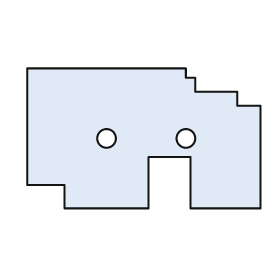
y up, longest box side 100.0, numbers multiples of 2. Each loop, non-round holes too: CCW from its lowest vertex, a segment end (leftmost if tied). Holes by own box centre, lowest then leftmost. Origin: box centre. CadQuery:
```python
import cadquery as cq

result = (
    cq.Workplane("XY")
    .moveTo(-34.0, -30.0)
    .lineTo(2.0, -30.0)
    .lineTo(2.0, -8.0)
    .lineTo(20.0, -8.0)
    .lineTo(20.0, -30.0)
    .lineTo(50.0, -30.0)
    .lineTo(50.0, 14.0)
    .lineTo(40.0, 14.0)
    .lineTo(40.0, 20.0)
    .lineTo(22.0, 20.0)
    .lineTo(22.0, 26.0)
    .lineTo(18.0, 26.0)
    .lineTo(18.0, 30.0)
    .lineTo(-50.0, 30.0)
    .lineTo(-50.0, -20.0)
    .lineTo(-34.0, -20.0)
    .close()
    .moveTo(-16.0, 0.0)
    .circle(4.0)
    .moveTo(18.0, 0.0)
    .circle(4.0)
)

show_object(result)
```